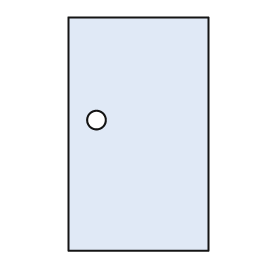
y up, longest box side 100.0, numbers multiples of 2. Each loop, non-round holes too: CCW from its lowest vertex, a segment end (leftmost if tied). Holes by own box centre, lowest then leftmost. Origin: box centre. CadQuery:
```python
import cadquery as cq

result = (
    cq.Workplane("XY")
    .moveTo(-30.0, -50.0)
    .lineTo(30.0, -50.0)
    .lineTo(30.0, 50.0)
    .lineTo(-30.0, 50.0)
    .close()
    .moveTo(-18.0, 6.0)
    .circle(4.0)
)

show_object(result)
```